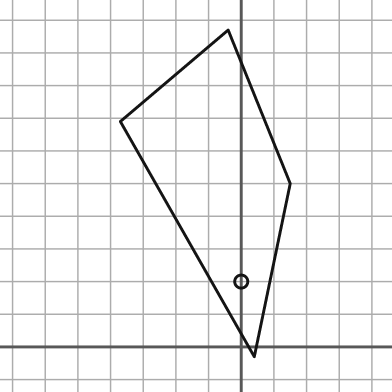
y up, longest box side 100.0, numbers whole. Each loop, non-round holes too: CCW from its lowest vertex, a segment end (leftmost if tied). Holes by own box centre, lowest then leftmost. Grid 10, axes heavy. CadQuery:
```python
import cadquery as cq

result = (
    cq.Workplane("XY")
    .moveTo(4.0, -3.0)
    .lineTo(15.0, 50.0)
    .lineTo(-4.0, 97.0)
    .lineTo(-37.0, 69.0)
    .close()
    .moveTo(0.0, 20.0)
    .circle(2.0)
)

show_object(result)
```